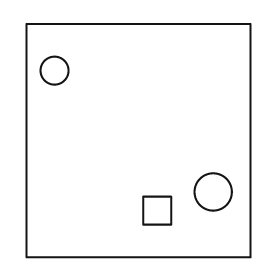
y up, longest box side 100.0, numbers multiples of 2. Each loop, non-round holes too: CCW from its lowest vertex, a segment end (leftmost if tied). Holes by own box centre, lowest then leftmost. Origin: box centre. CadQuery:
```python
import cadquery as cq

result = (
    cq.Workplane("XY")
    .moveTo(-48.0, -50.0)
    .lineTo(48.0, -50.0)
    .lineTo(48.0, 50.0)
    .lineTo(-48.0, 50.0)
    .close()
    .moveTo(2.0, -36.0)
    .lineTo(14.0, -36.0)
    .lineTo(14.0, -24.0)
    .lineTo(2.0, -24.0)
    .close()
    .moveTo(32.0, -22.0)
    .circle(8.0)
    .moveTo(-36.0, 30.0)
    .circle(6.0)
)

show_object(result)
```